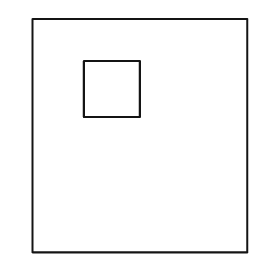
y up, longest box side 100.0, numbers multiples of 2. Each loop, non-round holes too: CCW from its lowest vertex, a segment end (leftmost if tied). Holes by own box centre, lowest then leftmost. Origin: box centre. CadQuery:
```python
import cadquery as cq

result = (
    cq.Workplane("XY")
    .moveTo(-46.0, -50.0)
    .lineTo(46.0, -50.0)
    .lineTo(46.0, 50.0)
    .lineTo(-46.0, 50.0)
    .close()
    .moveTo(-24.0, 8.0)
    .lineTo(0.0, 8.0)
    .lineTo(0.0, 32.0)
    .lineTo(-24.0, 32.0)
    .close()
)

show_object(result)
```